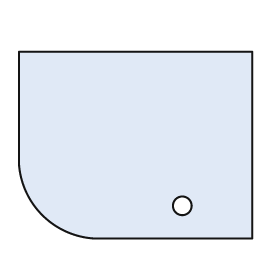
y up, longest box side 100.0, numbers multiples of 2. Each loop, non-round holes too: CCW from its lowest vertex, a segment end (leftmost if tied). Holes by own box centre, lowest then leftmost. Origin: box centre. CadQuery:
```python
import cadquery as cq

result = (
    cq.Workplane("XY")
    .moveTo(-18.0, -40.0)
    .lineTo(50.0, -40.0)
    .lineTo(50.0, 40.0)
    .lineTo(-50.0, 40.0)
    .lineTo(-50.0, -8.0)
    .threePointArc((-40.0, -30.0), (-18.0, -40.0))
    .close()
    .moveTo(20.0, -26.0)
    .circle(4.0)
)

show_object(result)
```